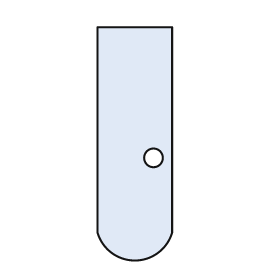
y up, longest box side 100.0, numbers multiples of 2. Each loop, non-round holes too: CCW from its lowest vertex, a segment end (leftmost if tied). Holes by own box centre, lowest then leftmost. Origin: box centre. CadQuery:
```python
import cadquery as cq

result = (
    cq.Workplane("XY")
    .moveTo(-16.0, -38.0)
    .threePointArc((0.0, -50.0), (16.0, -38.0))
    .lineTo(16.0, 50.0)
    .lineTo(-16.0, 50.0)
    .close()
    .moveTo(8.0, -6.0)
    .circle(4.0)
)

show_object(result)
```